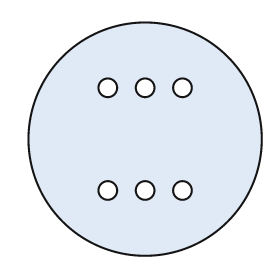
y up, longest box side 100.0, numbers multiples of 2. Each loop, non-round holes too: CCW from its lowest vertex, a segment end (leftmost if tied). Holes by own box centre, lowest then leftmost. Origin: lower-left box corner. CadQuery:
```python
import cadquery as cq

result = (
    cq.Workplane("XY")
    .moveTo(50.0, 50.0)
    .circle(50.0)
    .moveTo(34.0, 28.0)
    .circle(4.0)
    .moveTo(50.0, 28.0)
    .circle(4.0)
    .moveTo(66.0, 28.0)
    .circle(4.0)
    .moveTo(34.0, 72.0)
    .circle(4.0)
    .moveTo(50.0, 72.0)
    .circle(4.0)
    .moveTo(66.0, 72.0)
    .circle(4.0)
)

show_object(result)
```